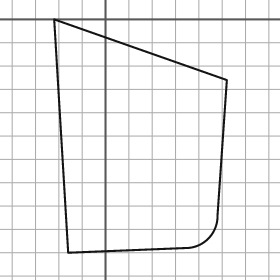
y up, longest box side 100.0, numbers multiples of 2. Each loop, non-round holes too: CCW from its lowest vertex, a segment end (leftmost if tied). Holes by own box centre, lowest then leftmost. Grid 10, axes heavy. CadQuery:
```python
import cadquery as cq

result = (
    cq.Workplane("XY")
    .moveTo(-16.0, -100.0)
    .lineTo(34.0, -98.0)
    .threePointArc((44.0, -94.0), (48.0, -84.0))
    .lineTo(52.0, -26.0)
    .lineTo(-22.0, 0.0)
    .close()
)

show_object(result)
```